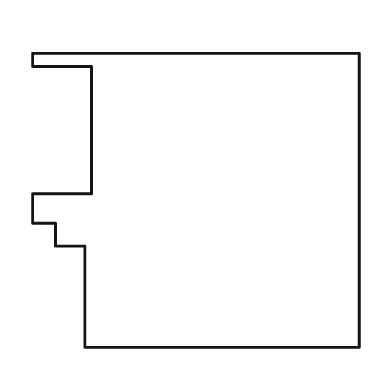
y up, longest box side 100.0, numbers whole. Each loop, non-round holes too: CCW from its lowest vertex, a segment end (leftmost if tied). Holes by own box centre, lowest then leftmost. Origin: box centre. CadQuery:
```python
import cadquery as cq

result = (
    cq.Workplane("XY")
    .moveTo(-34.0, -45.0)
    .lineTo(50.0, -45.0)
    .lineTo(50.0, 45.0)
    .lineTo(-50.0, 45.0)
    .lineTo(-50.0, 41.0)
    .lineTo(-32.0, 41.0)
    .lineTo(-32.0, 2.0)
    .lineTo(-50.0, 2.0)
    .lineTo(-50.0, -7.0)
    .lineTo(-43.0, -7.0)
    .lineTo(-43.0, -14.0)
    .lineTo(-34.0, -14.0)
    .close()
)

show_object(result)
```